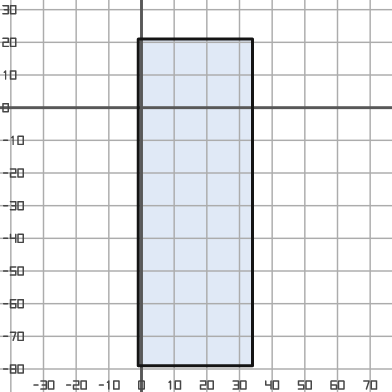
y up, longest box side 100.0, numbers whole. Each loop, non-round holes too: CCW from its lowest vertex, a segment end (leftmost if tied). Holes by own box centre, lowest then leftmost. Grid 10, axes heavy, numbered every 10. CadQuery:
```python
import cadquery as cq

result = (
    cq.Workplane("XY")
    .moveTo(-1.0, -79.0)
    .lineTo(34.0, -79.0)
    .lineTo(34.0, 21.0)
    .lineTo(-1.0, 21.0)
    .close()
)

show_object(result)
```